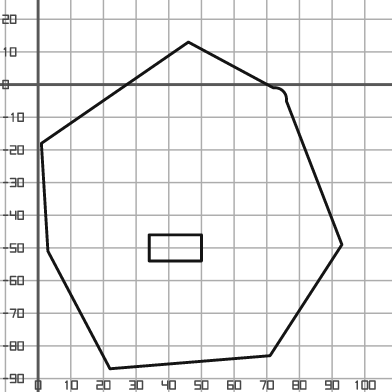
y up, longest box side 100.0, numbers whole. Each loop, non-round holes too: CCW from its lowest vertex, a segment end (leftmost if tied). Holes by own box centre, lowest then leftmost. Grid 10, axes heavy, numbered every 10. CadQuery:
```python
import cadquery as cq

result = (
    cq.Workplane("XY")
    .moveTo(22.0, -87.0)
    .lineTo(71.0, -83.0)
    .lineTo(93.0, -49.0)
    .lineTo(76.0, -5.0)
    .threePointArc((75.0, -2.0), (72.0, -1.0))
    .lineTo(46.0, 13.0)
    .lineTo(1.0, -18.0)
    .lineTo(3.0, -51.0)
    .close()
    .moveTo(34.0, -54.0)
    .lineTo(50.0, -54.0)
    .lineTo(50.0, -46.0)
    .lineTo(34.0, -46.0)
    .close()
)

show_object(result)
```